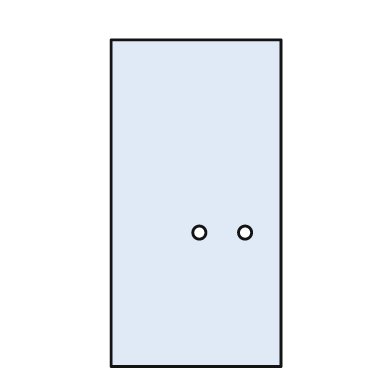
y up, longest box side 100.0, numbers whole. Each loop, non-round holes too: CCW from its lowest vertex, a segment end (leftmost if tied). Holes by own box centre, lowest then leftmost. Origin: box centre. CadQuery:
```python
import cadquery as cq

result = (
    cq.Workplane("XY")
    .moveTo(-26.0, -50.0)
    .lineTo(26.0, -50.0)
    .lineTo(26.0, 50.0)
    .lineTo(-26.0, 50.0)
    .close()
    .moveTo(1.0, -9.0)
    .circle(2.0)
    .moveTo(15.0, -9.0)
    .circle(2.0)
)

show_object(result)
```